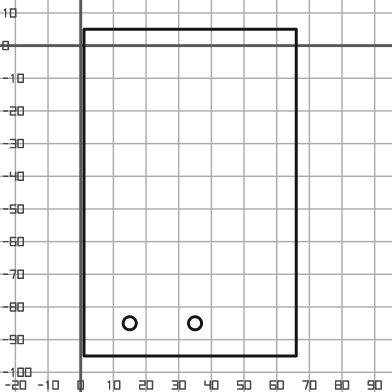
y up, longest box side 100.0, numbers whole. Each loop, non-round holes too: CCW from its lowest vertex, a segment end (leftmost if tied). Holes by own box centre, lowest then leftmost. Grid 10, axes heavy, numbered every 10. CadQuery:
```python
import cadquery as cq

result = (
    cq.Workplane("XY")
    .moveTo(1.0, -95.0)
    .lineTo(66.0, -95.0)
    .lineTo(66.0, 5.0)
    .lineTo(1.0, 5.0)
    .close()
    .moveTo(15.0, -85.0)
    .circle(2.0)
    .moveTo(35.0, -85.0)
    .circle(2.0)
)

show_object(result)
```